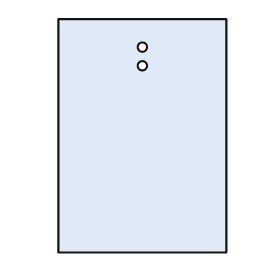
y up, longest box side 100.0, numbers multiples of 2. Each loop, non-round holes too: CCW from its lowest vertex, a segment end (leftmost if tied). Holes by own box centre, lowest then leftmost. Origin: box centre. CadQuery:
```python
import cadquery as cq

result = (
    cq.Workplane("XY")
    .moveTo(-36.0, -50.0)
    .lineTo(36.0, -50.0)
    .lineTo(36.0, 50.0)
    .lineTo(-36.0, 50.0)
    .close()
    .moveTo(0.0, 30.0)
    .circle(2.0)
    .moveTo(0.0, 38.0)
    .circle(2.0)
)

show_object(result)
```